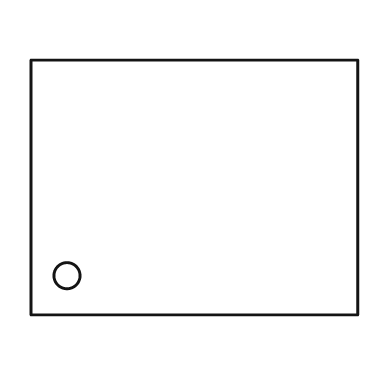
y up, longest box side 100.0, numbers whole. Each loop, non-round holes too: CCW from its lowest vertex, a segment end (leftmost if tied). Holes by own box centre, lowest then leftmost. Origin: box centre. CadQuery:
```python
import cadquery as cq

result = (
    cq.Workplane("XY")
    .moveTo(-50.0, -39.0)
    .lineTo(50.0, -39.0)
    .lineTo(50.0, 39.0)
    .lineTo(-50.0, 39.0)
    .close()
    .moveTo(-39.0, -27.0)
    .circle(4.0)
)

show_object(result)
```